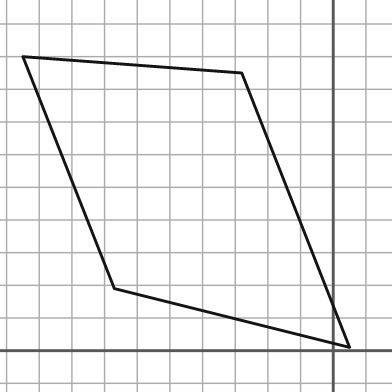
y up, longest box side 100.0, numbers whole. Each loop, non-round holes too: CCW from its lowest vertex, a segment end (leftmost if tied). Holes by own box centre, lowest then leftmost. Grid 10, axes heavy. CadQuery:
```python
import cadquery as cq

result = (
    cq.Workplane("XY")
    .moveTo(5.0, 1.0)
    .lineTo(-28.0, 85.0)
    .lineTo(-95.0, 90.0)
    .lineTo(-67.0, 19.0)
    .close()
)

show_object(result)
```